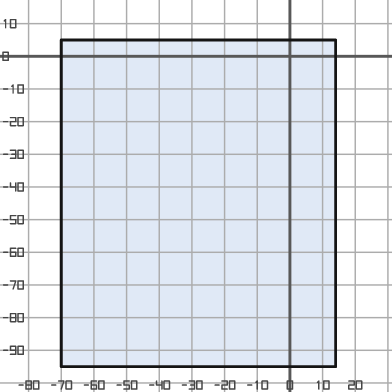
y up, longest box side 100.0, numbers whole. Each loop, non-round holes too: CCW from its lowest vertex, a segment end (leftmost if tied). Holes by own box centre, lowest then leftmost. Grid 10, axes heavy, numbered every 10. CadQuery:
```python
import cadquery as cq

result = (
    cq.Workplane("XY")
    .moveTo(-70.0, -95.0)
    .lineTo(14.0, -95.0)
    .lineTo(14.0, 5.0)
    .lineTo(-70.0, 5.0)
    .close()
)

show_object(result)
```